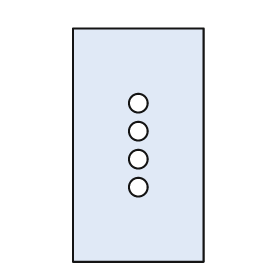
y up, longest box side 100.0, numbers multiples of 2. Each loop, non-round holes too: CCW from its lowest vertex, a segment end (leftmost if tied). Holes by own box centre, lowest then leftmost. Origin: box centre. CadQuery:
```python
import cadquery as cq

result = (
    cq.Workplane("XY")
    .moveTo(-28.0, -50.0)
    .lineTo(28.0, -50.0)
    .lineTo(28.0, 50.0)
    .lineTo(-28.0, 50.0)
    .close()
    .moveTo(0.0, -18.0)
    .circle(4.0)
    .moveTo(0.0, -6.0)
    .circle(4.0)
    .moveTo(0.0, 6.0)
    .circle(4.0)
    .moveTo(0.0, 18.0)
    .circle(4.0)
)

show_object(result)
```